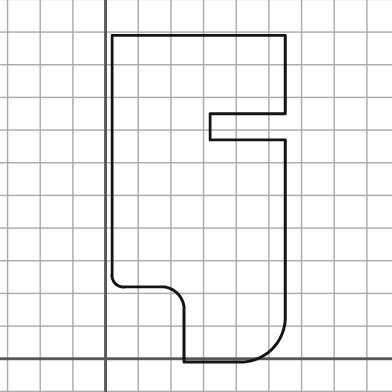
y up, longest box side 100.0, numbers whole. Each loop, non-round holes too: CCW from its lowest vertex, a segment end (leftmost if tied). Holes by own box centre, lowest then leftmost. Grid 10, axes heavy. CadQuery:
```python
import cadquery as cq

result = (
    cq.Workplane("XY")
    .moveTo(24.0, -1.0)
    .lineTo(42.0, -1.0)
    .threePointArc((51.0, 3.0), (55.0, 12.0))
    .lineTo(55.0, 67.0)
    .lineTo(32.0, 67.0)
    .lineTo(32.0, 75.0)
    .lineTo(55.0, 75.0)
    .lineTo(55.0, 99.0)
    .lineTo(2.0, 99.0)
    .lineTo(2.0, 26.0)
    .threePointArc((3.0, 23.0), (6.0, 22.0))
    .lineTo(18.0, 22.0)
    .threePointArc((22.0, 20.0), (24.0, 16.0))
    .close()
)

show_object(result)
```